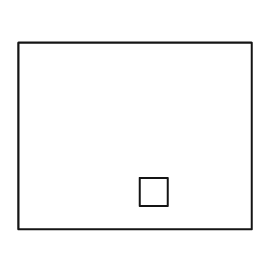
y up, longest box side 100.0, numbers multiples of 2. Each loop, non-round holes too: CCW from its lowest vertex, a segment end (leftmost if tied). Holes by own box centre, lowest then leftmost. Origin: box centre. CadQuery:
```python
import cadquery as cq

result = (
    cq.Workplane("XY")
    .moveTo(-50.0, -40.0)
    .lineTo(50.0, -40.0)
    .lineTo(50.0, 40.0)
    .lineTo(-50.0, 40.0)
    .close()
    .moveTo(2.0, -30.0)
    .lineTo(14.0, -30.0)
    .lineTo(14.0, -18.0)
    .lineTo(2.0, -18.0)
    .close()
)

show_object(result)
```